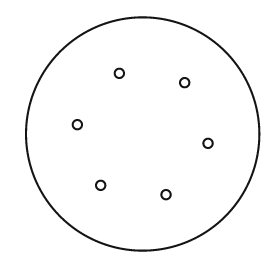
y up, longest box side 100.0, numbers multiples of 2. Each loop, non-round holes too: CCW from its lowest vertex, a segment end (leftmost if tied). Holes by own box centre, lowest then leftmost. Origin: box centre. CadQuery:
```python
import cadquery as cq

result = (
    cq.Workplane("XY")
    .moveTo(0.0, 0.0)
    .circle(50.0)
    .moveTo(10.0, -26.0)
    .circle(2.0)
    .moveTo(-18.0, -22.0)
    .circle(2.0)
    .moveTo(28.0, -4.0)
    .circle(2.0)
    .moveTo(-28.0, 4.0)
    .circle(2.0)
    .moveTo(18.0, 22.0)
    .circle(2.0)
    .moveTo(-10.0, 26.0)
    .circle(2.0)
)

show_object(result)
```